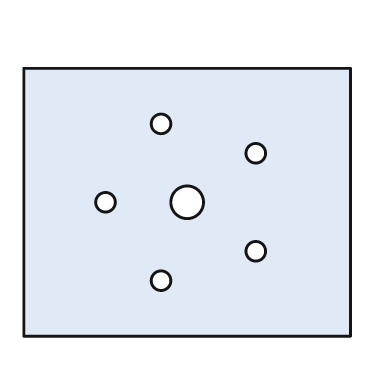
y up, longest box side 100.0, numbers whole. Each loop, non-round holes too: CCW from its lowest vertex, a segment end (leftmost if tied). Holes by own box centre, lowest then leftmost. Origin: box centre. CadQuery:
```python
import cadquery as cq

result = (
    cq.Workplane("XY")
    .moveTo(-50.0, -41.0)
    .lineTo(50.0, -41.0)
    .lineTo(50.0, 41.0)
    .lineTo(-50.0, 41.0)
    .close()
    .moveTo(-8.0, -24.0)
    .circle(3.0)
    .moveTo(21.0, -15.0)
    .circle(3.0)
    .moveTo(-25.0, 0.0)
    .circle(3.0)
    .moveTo(0.0, 0.0)
    .circle(5.0)
    .moveTo(21.0, 15.0)
    .circle(3.0)
    .moveTo(-8.0, 24.0)
    .circle(3.0)
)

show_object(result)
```